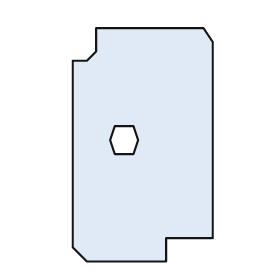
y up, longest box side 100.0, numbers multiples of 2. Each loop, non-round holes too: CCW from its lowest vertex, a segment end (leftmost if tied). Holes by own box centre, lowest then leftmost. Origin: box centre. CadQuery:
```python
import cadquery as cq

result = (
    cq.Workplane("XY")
    .moveTo(-24.0, -50.0)
    .lineTo(10.0, -50.0)
    .lineTo(10.0, -40.0)
    .lineTo(30.0, -40.0)
    .lineTo(30.0, 44.0)
    .lineTo(26.0, 50.0)
    .lineTo(-20.0, 50.0)
    .lineTo(-20.0, 40.0)
    .lineTo(-24.0, 36.0)
    .lineTo(-30.0, 36.0)
    .lineTo(-30.0, -44.0)
    .close()
    .moveTo(-12.0, -4.0)
    .lineTo(-4.0, -4.0)
    .lineTo(-2.0, 2.0)
    .lineTo(-4.0, 8.0)
    .lineTo(-12.0, 8.0)
    .lineTo(-14.0, 2.0)
    .close()
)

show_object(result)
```